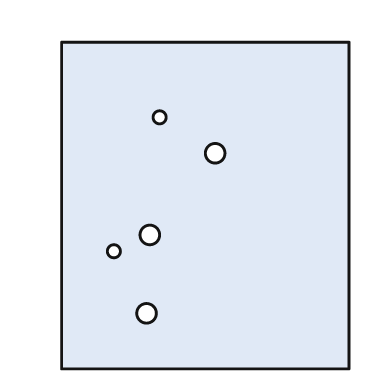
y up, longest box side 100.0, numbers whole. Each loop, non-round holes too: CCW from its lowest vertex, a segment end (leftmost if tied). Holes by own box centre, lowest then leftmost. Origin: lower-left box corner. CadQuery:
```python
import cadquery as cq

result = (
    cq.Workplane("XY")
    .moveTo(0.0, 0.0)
    .lineTo(88.0, 0.0)
    .lineTo(88.0, 100.0)
    .lineTo(0.0, 100.0)
    .close()
    .moveTo(26.0, 17.0)
    .circle(3.0)
    .moveTo(16.0, 36.0)
    .circle(2.0)
    .moveTo(27.0, 41.0)
    .circle(3.0)
    .moveTo(47.0, 66.0)
    .circle(3.0)
    .moveTo(30.0, 77.0)
    .circle(2.0)
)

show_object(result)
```